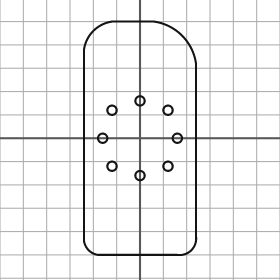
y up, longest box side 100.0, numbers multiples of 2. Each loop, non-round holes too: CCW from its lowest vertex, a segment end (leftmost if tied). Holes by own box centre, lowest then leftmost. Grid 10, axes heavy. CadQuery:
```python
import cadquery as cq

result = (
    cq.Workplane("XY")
    .moveTo(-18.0, -50.0)
    .lineTo(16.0, -50.0)
    .threePointArc((22.0, -48.0), (24.0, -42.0))
    .lineTo(24.0, 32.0)
    .threePointArc((18.0, 44.0), (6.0, 50.0))
    .lineTo(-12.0, 50.0)
    .threePointArc((-20.0, 46.0), (-24.0, 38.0))
    .lineTo(-24.0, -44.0)
    .threePointArc((-22.0, -48.0), (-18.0, -50.0))
    .close()
    .moveTo(0.0, -16.0)
    .circle(2.0)
    .moveTo(-12.0, -12.0)
    .circle(2.0)
    .moveTo(12.0, -12.0)
    .circle(2.0)
    .moveTo(-16.0, 0.0)
    .circle(2.0)
    .moveTo(16.0, 0.0)
    .circle(2.0)
    .moveTo(-12.0, 12.0)
    .circle(2.0)
    .moveTo(12.0, 12.0)
    .circle(2.0)
    .moveTo(0.0, 16.0)
    .circle(2.0)
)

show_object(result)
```